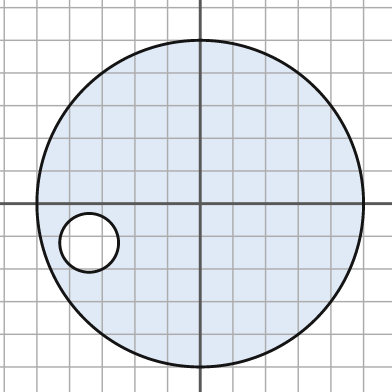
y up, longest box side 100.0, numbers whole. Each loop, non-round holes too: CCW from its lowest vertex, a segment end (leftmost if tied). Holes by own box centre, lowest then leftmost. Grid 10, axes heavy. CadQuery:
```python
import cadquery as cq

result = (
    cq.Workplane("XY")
    .moveTo(0.0, 0.0)
    .circle(50.0)
    .moveTo(-34.0, -12.0)
    .circle(9.0)
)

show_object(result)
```